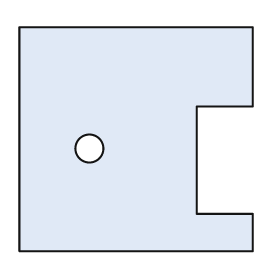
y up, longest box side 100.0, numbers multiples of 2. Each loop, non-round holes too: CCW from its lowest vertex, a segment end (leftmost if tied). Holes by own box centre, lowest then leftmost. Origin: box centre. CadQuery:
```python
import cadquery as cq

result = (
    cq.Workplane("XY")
    .moveTo(-50.0, -48.0)
    .lineTo(50.0, -48.0)
    .lineTo(50.0, -32.0)
    .lineTo(26.0, -32.0)
    .lineTo(26.0, 14.0)
    .lineTo(50.0, 14.0)
    .lineTo(50.0, 48.0)
    .lineTo(-50.0, 48.0)
    .close()
    .moveTo(-20.0, -4.0)
    .circle(6.0)
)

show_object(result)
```